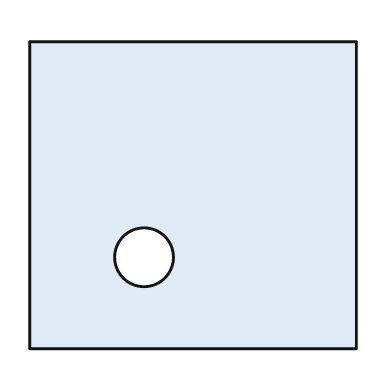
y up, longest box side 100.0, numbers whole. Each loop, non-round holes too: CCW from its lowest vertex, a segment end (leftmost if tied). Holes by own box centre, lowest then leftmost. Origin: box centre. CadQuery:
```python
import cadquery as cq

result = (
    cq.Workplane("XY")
    .moveTo(-50.0, -47.0)
    .lineTo(50.0, -47.0)
    .lineTo(50.0, 47.0)
    .lineTo(-50.0, 47.0)
    .close()
    .moveTo(-15.0, -19.0)
    .circle(9.0)
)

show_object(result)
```